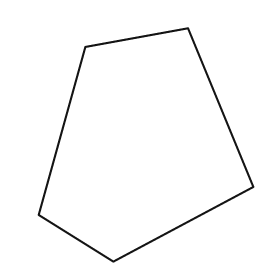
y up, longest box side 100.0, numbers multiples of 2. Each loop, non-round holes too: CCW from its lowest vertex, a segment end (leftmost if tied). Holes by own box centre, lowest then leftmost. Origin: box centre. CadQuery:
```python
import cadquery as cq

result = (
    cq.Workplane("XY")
    .moveTo(-14.0, -50.0)
    .lineTo(46.0, -18.0)
    .lineTo(18.0, 50.0)
    .lineTo(-26.0, 42.0)
    .lineTo(-46.0, -30.0)
    .close()
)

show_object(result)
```